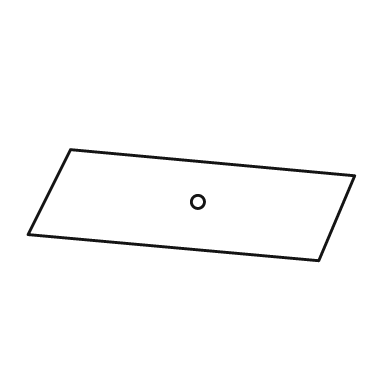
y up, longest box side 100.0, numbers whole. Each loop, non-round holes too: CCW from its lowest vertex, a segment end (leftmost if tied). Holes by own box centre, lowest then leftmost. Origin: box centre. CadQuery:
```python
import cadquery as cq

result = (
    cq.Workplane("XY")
    .moveTo(39.0, -17.0)
    .lineTo(50.0, 9.0)
    .lineTo(-37.0, 17.0)
    .lineTo(-50.0, -9.0)
    .close()
    .moveTo(2.0, 1.0)
    .circle(2.0)
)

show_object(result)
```